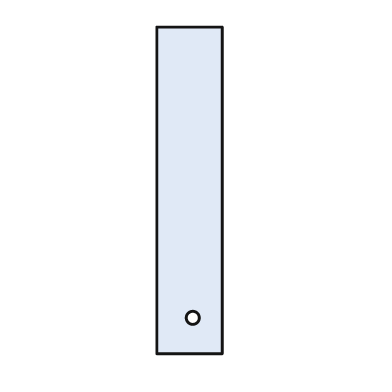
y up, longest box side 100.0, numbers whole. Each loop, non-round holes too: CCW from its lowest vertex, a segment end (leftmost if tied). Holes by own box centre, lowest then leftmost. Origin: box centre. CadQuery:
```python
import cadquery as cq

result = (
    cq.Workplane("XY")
    .moveTo(-10.0, -50.0)
    .lineTo(10.0, -50.0)
    .lineTo(10.0, 50.0)
    .lineTo(-10.0, 50.0)
    .close()
    .moveTo(1.0, -39.0)
    .circle(2.0)
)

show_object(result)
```